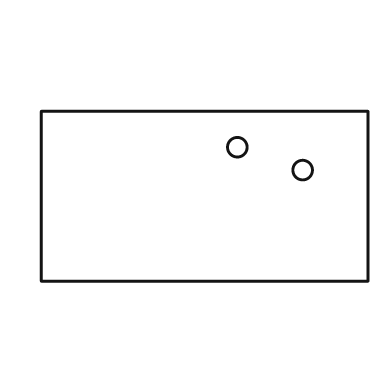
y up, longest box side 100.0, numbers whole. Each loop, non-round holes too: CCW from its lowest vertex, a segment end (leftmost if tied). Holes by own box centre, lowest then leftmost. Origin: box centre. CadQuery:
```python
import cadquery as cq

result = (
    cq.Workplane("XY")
    .moveTo(-50.0, -26.0)
    .lineTo(50.0, -26.0)
    .lineTo(50.0, 26.0)
    .lineTo(-50.0, 26.0)
    .close()
    .moveTo(30.0, 8.0)
    .circle(3.0)
    .moveTo(10.0, 15.0)
    .circle(3.0)
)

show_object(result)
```